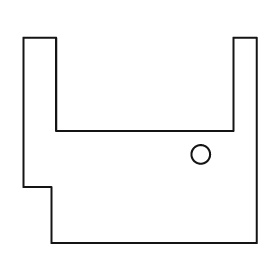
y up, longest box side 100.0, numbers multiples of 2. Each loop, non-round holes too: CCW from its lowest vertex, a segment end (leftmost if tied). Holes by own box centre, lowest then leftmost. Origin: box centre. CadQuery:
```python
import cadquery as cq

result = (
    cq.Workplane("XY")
    .moveTo(-38.0, -44.0)
    .lineTo(50.0, -44.0)
    .lineTo(50.0, 44.0)
    .lineTo(40.0, 44.0)
    .lineTo(40.0, 4.0)
    .lineTo(-36.0, 4.0)
    .lineTo(-36.0, 44.0)
    .lineTo(-50.0, 44.0)
    .lineTo(-50.0, -20.0)
    .lineTo(-38.0, -20.0)
    .close()
    .moveTo(26.0, -6.0)
    .circle(4.0)
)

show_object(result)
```